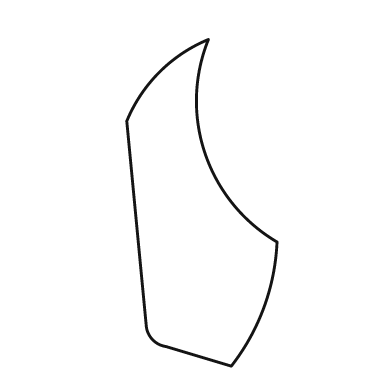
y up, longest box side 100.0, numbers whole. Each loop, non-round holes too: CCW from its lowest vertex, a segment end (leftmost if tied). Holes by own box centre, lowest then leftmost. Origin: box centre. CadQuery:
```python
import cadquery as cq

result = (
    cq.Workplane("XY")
    .moveTo(9.0, -50.0)
    .threePointArc((19.0, -32.0), (23.0, -12.0))
    .threePointArc((1.0, 15.0), (2.0, 50.0))
    .threePointArc((-13.0, 40.0), (-23.0, 25.0))
    .lineTo(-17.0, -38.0)
    .threePointArc((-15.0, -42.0), (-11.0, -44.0))
    .close()
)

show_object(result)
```